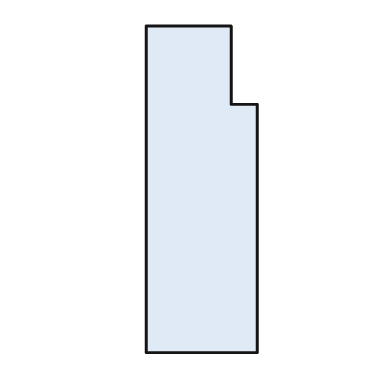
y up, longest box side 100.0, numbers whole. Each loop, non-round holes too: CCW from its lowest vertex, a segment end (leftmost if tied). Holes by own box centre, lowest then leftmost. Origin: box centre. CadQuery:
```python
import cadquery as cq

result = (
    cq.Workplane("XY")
    .moveTo(-17.0, -50.0)
    .lineTo(17.0, -50.0)
    .lineTo(17.0, 26.0)
    .lineTo(9.0, 26.0)
    .lineTo(9.0, 50.0)
    .lineTo(-17.0, 50.0)
    .close()
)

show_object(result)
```